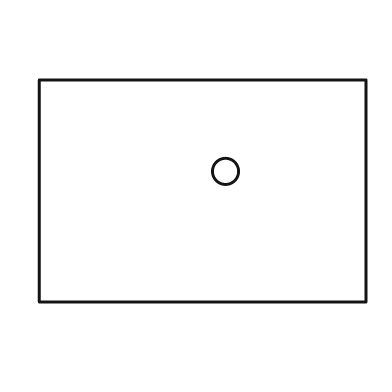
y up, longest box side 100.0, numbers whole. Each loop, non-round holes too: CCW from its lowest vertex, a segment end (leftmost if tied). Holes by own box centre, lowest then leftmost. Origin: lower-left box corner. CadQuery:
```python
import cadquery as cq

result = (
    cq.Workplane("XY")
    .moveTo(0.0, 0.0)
    .lineTo(100.0, 0.0)
    .lineTo(100.0, 68.0)
    .lineTo(0.0, 68.0)
    .close()
    .moveTo(57.0, 40.0)
    .circle(4.0)
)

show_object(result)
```